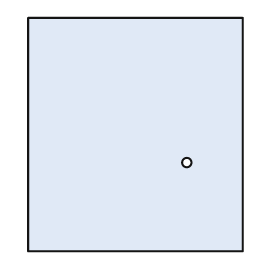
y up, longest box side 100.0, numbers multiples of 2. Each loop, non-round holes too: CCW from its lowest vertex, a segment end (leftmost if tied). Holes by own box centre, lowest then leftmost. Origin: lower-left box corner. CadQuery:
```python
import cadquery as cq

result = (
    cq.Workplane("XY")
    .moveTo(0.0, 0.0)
    .lineTo(92.0, 0.0)
    .lineTo(92.0, 100.0)
    .lineTo(0.0, 100.0)
    .close()
    .moveTo(68.0, 38.0)
    .circle(2.0)
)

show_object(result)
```